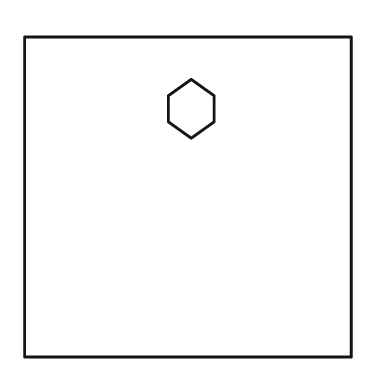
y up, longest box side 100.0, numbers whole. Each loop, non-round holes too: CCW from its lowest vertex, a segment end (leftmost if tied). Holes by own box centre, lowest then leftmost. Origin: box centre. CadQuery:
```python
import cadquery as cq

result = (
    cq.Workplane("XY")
    .moveTo(-50.0, -49.0)
    .lineTo(50.0, -49.0)
    .lineTo(50.0, 49.0)
    .lineTo(-50.0, 49.0)
    .close()
    .moveTo(1.0, 18.0)
    .lineTo(8.0, 23.0)
    .lineTo(8.0, 31.0)
    .lineTo(1.0, 36.0)
    .lineTo(-6.0, 31.0)
    .lineTo(-6.0, 23.0)
    .close()
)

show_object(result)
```